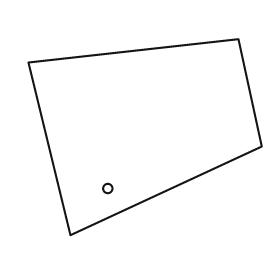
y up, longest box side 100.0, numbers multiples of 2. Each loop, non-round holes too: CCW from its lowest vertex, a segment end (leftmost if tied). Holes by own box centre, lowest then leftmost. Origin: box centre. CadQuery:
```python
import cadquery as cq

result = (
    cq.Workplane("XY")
    .moveTo(-32.0, -42.0)
    .lineTo(50.0, -4.0)
    .lineTo(40.0, 42.0)
    .lineTo(-50.0, 32.0)
    .close()
    .moveTo(-16.0, -22.0)
    .circle(2.0)
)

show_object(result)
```